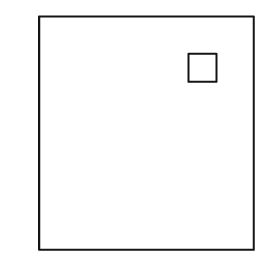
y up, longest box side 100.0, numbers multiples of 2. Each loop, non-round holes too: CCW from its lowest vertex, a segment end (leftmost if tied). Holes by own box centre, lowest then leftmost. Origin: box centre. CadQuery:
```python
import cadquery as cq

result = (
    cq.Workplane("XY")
    .moveTo(-46.0, -50.0)
    .lineTo(46.0, -50.0)
    .lineTo(46.0, 50.0)
    .lineTo(-46.0, 50.0)
    .close()
    .moveTo(18.0, 22.0)
    .lineTo(30.0, 22.0)
    .lineTo(30.0, 34.0)
    .lineTo(18.0, 34.0)
    .close()
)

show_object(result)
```